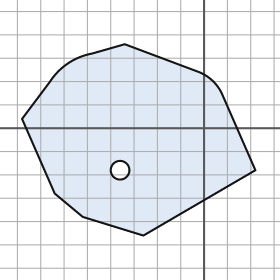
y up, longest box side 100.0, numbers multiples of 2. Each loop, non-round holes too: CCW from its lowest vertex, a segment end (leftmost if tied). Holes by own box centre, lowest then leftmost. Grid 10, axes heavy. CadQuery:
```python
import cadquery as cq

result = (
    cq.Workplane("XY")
    .moveTo(-26.0, -46.0)
    .lineTo(22.0, -18.0)
    .lineTo(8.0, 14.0)
    .threePointArc((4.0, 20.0), (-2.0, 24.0))
    .lineTo(-34.0, 36.0)
    .lineTo(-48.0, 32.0)
    .threePointArc((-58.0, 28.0), (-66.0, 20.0))
    .lineTo(-78.0, 4.0)
    .lineTo(-64.0, -28.0)
    .lineTo(-52.0, -38.0)
    .close()
    .moveTo(-36.0, -18.0)
    .circle(4.0)
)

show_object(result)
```